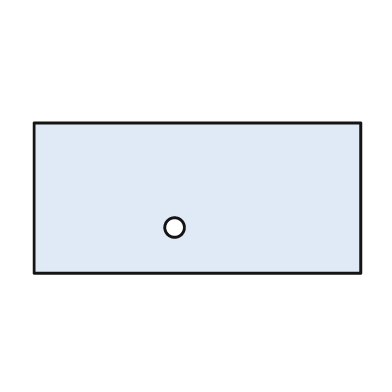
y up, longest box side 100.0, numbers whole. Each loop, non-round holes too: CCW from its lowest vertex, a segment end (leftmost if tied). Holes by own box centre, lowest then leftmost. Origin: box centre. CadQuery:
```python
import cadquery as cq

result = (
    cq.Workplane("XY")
    .moveTo(-50.0, -23.0)
    .lineTo(50.0, -23.0)
    .lineTo(50.0, 23.0)
    .lineTo(-50.0, 23.0)
    .close()
    .moveTo(-7.0, -9.0)
    .circle(3.0)
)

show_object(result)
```